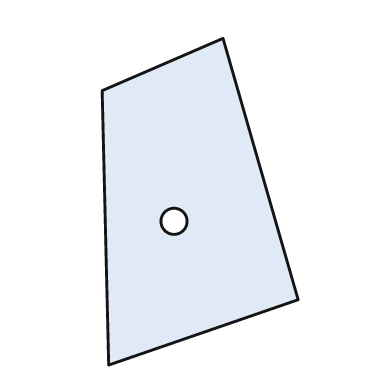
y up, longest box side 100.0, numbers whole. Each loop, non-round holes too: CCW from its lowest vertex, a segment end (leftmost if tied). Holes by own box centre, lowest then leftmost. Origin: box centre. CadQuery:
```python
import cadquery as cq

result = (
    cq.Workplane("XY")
    .moveTo(-28.0, -50.0)
    .lineTo(30.0, -30.0)
    .lineTo(7.0, 50.0)
    .lineTo(-30.0, 34.0)
    .close()
    .moveTo(-8.0, -6.0)
    .circle(4.0)
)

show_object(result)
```